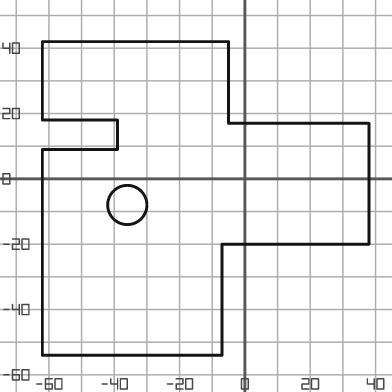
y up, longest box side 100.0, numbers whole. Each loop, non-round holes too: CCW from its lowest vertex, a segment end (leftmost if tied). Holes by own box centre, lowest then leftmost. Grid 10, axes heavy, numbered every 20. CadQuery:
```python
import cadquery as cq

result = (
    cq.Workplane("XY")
    .moveTo(-62.0, -54.0)
    .lineTo(-7.0, -54.0)
    .lineTo(-7.0, -20.0)
    .lineTo(38.0, -20.0)
    .lineTo(38.0, 17.0)
    .lineTo(-5.0, 17.0)
    .lineTo(-5.0, 42.0)
    .lineTo(-62.0, 42.0)
    .lineTo(-62.0, 18.0)
    .lineTo(-39.0, 18.0)
    .lineTo(-39.0, 9.0)
    .lineTo(-62.0, 9.0)
    .close()
    .moveTo(-36.0, -8.0)
    .circle(6.0)
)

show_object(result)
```